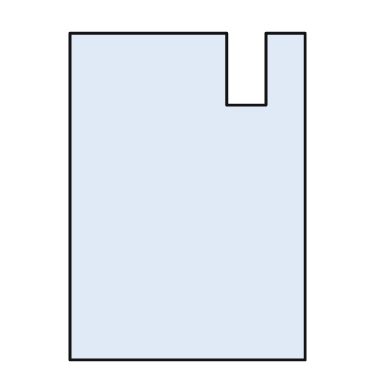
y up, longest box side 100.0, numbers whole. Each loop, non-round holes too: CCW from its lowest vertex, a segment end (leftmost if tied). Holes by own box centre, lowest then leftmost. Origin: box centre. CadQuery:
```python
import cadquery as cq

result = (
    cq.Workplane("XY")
    .moveTo(-36.0, -50.0)
    .lineTo(36.0, -50.0)
    .lineTo(36.0, 50.0)
    .lineTo(24.0, 50.0)
    .lineTo(24.0, 28.0)
    .lineTo(12.0, 28.0)
    .lineTo(12.0, 50.0)
    .lineTo(-36.0, 50.0)
    .close()
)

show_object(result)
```